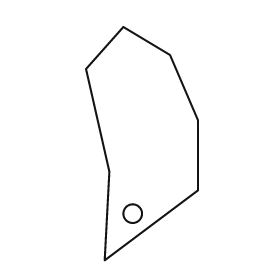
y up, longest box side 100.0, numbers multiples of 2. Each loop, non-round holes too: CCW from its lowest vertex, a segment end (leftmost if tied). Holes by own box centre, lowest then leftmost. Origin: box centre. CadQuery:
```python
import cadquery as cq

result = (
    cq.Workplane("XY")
    .moveTo(-16.0, -50.0)
    .lineTo(24.0, -20.0)
    .lineTo(24.0, 10.0)
    .lineTo(12.0, 38.0)
    .lineTo(-8.0, 50.0)
    .lineTo(-24.0, 32.0)
    .lineTo(-14.0, -12.0)
    .close()
    .moveTo(-4.0, -30.0)
    .circle(4.0)
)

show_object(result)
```